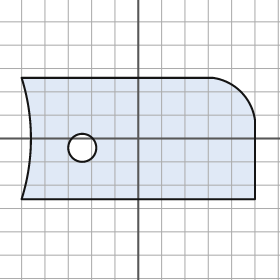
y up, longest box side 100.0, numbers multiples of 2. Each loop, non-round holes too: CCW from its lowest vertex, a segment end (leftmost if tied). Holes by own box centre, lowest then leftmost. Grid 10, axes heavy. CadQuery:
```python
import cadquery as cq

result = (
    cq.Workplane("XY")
    .moveTo(-50.0, -26.0)
    .lineTo(50.0, -26.0)
    .lineTo(50.0, 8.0)
    .threePointArc((44.0, 20.0), (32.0, 26.0))
    .lineTo(-50.0, 26.0)
    .threePointArc((-46.0, 0.0), (-50.0, -26.0))
    .close()
    .moveTo(-24.0, -4.0)
    .circle(6.0)
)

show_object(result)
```